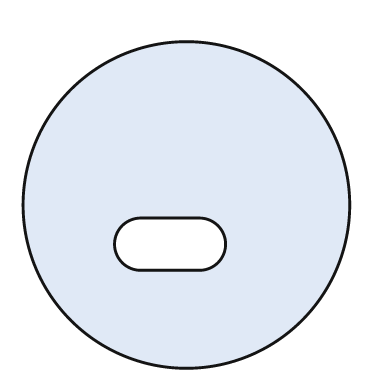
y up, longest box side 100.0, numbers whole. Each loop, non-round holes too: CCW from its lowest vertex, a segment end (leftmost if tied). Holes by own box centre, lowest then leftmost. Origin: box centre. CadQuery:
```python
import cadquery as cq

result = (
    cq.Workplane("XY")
    .moveTo(0.0, 0.0)
    .circle(50.0)
    .moveTo(-14.0, -20.0)
    .lineTo(4.0, -20.0)
    .threePointArc((12.0, -12.0), (4.0, -4.0))
    .lineTo(-14.0, -4.0)
    .threePointArc((-22.0, -12.0), (-14.0, -20.0))
    .close()
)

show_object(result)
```